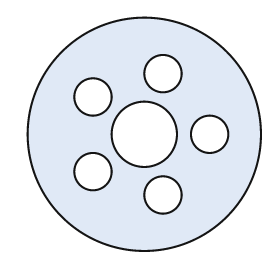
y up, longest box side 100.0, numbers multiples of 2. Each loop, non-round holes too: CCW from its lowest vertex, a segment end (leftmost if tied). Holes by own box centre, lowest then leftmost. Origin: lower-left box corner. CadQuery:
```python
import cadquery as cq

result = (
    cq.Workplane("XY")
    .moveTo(50.0, 50.0)
    .circle(50.0)
    .moveTo(58.0, 24.0)
    .circle(8.0)
    .moveTo(28.0, 34.0)
    .circle(8.0)
    .moveTo(50.0, 50.0)
    .circle(14.0)
    .moveTo(78.0, 50.0)
    .circle(8.0)
    .moveTo(28.0, 66.0)
    .circle(8.0)
    .moveTo(58.0, 76.0)
    .circle(8.0)
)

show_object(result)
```